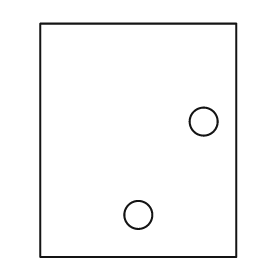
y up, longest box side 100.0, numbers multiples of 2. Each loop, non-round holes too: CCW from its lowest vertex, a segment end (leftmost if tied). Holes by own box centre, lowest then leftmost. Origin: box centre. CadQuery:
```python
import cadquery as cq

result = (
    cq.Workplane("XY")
    .moveTo(-42.0, -50.0)
    .lineTo(42.0, -50.0)
    .lineTo(42.0, 50.0)
    .lineTo(-42.0, 50.0)
    .close()
    .moveTo(0.0, -32.0)
    .circle(6.0)
    .moveTo(28.0, 8.0)
    .circle(6.0)
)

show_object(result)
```